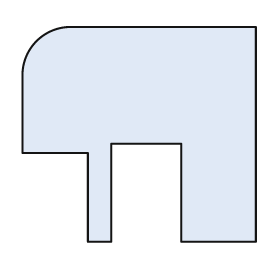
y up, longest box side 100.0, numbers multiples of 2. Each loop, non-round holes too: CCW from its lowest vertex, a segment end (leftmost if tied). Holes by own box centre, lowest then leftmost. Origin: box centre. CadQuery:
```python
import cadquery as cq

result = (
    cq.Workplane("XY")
    .moveTo(-22.0, -46.0)
    .lineTo(-12.0, -46.0)
    .lineTo(-12.0, -4.0)
    .lineTo(18.0, -4.0)
    .lineTo(18.0, -46.0)
    .lineTo(50.0, -46.0)
    .lineTo(50.0, 46.0)
    .lineTo(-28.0, 46.0)
    .threePointArc((-44.0, 40.0), (-50.0, 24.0))
    .lineTo(-50.0, -8.0)
    .lineTo(-22.0, -8.0)
    .close()
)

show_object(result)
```